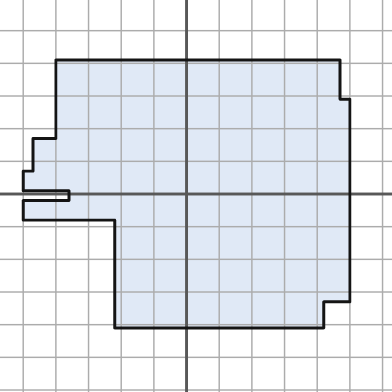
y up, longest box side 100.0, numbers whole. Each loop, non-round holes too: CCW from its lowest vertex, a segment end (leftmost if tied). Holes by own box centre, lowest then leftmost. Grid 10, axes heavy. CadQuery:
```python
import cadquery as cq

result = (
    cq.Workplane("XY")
    .moveTo(-22.0, -41.0)
    .lineTo(42.0, -41.0)
    .lineTo(42.0, -33.0)
    .lineTo(50.0, -33.0)
    .lineTo(50.0, 29.0)
    .lineTo(47.0, 29.0)
    .lineTo(47.0, 41.0)
    .lineTo(-40.0, 41.0)
    .lineTo(-40.0, 17.0)
    .lineTo(-47.0, 17.0)
    .lineTo(-47.0, 7.0)
    .lineTo(-50.0, 7.0)
    .lineTo(-50.0, 1.0)
    .lineTo(-36.0, 1.0)
    .lineTo(-36.0, -2.0)
    .lineTo(-50.0, -2.0)
    .lineTo(-50.0, -8.0)
    .lineTo(-22.0, -8.0)
    .close()
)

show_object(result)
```